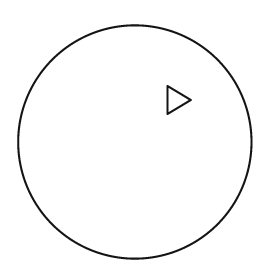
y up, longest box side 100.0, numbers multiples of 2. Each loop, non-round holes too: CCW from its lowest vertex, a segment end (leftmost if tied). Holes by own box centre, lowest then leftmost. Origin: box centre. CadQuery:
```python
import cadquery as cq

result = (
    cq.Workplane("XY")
    .moveTo(0.0, 0.0)
    .circle(50.0)
    .moveTo(14.0, 12.0)
    .lineTo(24.0, 18.0)
    .lineTo(14.0, 24.0)
    .close()
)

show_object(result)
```